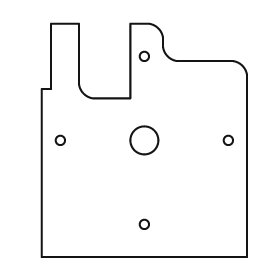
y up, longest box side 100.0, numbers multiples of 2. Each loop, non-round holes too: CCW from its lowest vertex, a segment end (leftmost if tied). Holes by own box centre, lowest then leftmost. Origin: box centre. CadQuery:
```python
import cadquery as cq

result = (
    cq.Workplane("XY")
    .moveTo(-44.0, -50.0)
    .lineTo(44.0, -50.0)
    .lineTo(44.0, 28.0)
    .threePointArc((42.0, 32.0), (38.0, 34.0))
    .lineTo(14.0, 34.0)
    .threePointArc((10.0, 36.0), (8.0, 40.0))
    .lineTo(8.0, 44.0)
    .threePointArc((6.0, 48.0), (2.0, 50.0))
    .lineTo(-6.0, 50.0)
    .lineTo(-6.0, 18.0)
    .lineTo(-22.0, 18.0)
    .threePointArc((-26.0, 20.0), (-28.0, 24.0))
    .lineTo(-28.0, 50.0)
    .lineTo(-40.0, 50.0)
    .lineTo(-40.0, 22.0)
    .lineTo(-44.0, 22.0)
    .close()
    .moveTo(0.0, -36.0)
    .circle(2.0)
    .moveTo(-36.0, 0.0)
    .circle(2.0)
    .moveTo(0.0, 0.0)
    .circle(6.0)
    .moveTo(36.0, 0.0)
    .circle(2.0)
    .moveTo(0.0, 36.0)
    .circle(2.0)
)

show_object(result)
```